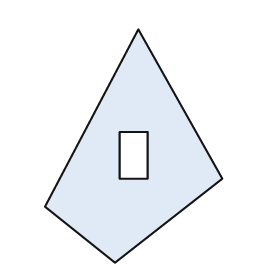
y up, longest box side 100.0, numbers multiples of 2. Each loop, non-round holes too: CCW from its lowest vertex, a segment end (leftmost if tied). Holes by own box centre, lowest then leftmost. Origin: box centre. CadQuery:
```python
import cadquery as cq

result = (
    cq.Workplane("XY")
    .moveTo(-8.0, -50.0)
    .lineTo(38.0, -14.0)
    .lineTo(2.0, 50.0)
    .lineTo(-38.0, -26.0)
    .close()
    .moveTo(-6.0, -14.0)
    .lineTo(6.0, -14.0)
    .lineTo(6.0, 6.0)
    .lineTo(-6.0, 6.0)
    .close()
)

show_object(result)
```